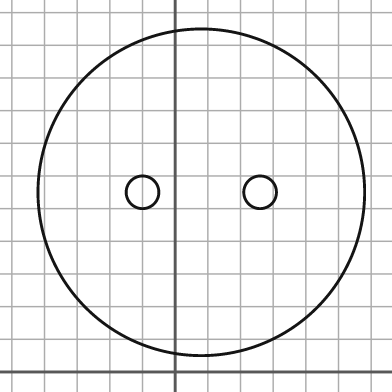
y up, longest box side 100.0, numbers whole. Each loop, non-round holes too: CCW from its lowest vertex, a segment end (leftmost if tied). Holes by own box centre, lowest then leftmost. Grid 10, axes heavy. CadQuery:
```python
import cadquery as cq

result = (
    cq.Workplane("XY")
    .moveTo(8.0, 55.0)
    .circle(50.0)
    .moveTo(-10.0, 55.0)
    .circle(5.0)
    .moveTo(26.0, 55.0)
    .circle(5.0)
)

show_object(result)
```